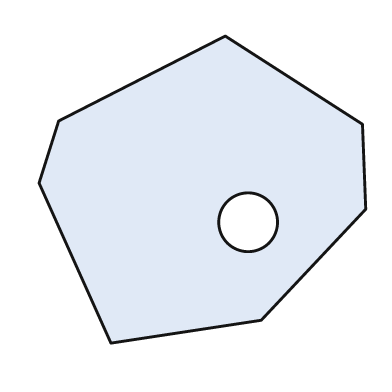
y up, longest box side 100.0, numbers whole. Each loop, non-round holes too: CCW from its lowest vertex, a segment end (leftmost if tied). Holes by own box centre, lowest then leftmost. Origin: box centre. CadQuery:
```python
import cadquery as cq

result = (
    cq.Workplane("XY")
    .moveTo(-28.0, -47.0)
    .lineTo(18.0, -40.0)
    .lineTo(50.0, -6.0)
    .lineTo(49.0, 20.0)
    .lineTo(7.0, 47.0)
    .lineTo(-44.0, 21.0)
    .lineTo(-50.0, 2.0)
    .close()
    .moveTo(14.0, -10.0)
    .circle(9.0)
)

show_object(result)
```